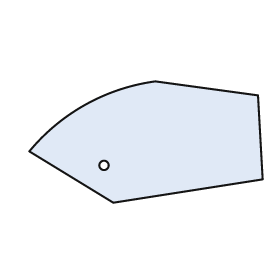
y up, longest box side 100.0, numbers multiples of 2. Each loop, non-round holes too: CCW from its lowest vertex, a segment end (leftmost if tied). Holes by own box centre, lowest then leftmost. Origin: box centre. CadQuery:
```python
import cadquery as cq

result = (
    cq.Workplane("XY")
    .moveTo(-14.0, -26.0)
    .lineTo(50.0, -16.0)
    .lineTo(48.0, 20.0)
    .lineTo(4.0, 26.0)
    .threePointArc((-26.0, 16.0), (-50.0, -4.0))
    .close()
    .moveTo(-18.0, -10.0)
    .circle(2.0)
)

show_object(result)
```